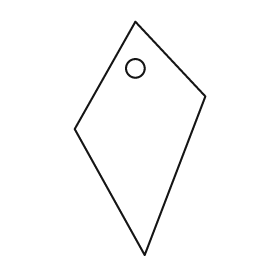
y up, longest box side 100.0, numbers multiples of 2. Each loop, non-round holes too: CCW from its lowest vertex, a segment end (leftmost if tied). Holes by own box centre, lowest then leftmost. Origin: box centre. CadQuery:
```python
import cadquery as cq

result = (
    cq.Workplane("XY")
    .moveTo(2.0, -50.0)
    .lineTo(28.0, 18.0)
    .lineTo(-2.0, 50.0)
    .lineTo(-28.0, 4.0)
    .close()
    .moveTo(-2.0, 30.0)
    .circle(4.0)
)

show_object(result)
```